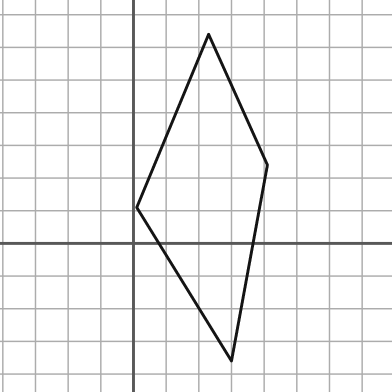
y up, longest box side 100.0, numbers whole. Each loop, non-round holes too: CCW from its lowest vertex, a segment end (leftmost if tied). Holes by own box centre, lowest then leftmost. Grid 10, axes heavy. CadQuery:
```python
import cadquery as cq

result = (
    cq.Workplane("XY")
    .moveTo(30.0, -36.0)
    .lineTo(41.0, 24.0)
    .lineTo(23.0, 64.0)
    .lineTo(1.0, 11.0)
    .close()
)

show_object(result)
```